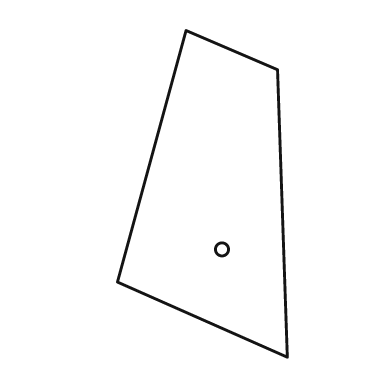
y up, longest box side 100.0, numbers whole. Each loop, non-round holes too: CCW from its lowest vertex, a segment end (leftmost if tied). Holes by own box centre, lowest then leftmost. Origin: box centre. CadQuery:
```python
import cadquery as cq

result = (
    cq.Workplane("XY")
    .moveTo(26.0, -50.0)
    .lineTo(23.0, 38.0)
    .lineTo(-5.0, 50.0)
    .lineTo(-26.0, -27.0)
    .close()
    .moveTo(6.0, -17.0)
    .circle(2.0)
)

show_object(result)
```